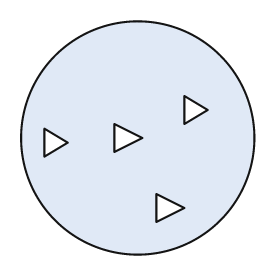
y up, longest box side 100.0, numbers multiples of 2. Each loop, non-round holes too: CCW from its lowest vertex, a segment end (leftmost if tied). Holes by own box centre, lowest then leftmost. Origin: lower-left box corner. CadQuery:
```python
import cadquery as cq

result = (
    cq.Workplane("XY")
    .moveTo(50.0, 50.0)
    .circle(50.0)
    .moveTo(58.0, 14.0)
    .lineTo(70.0, 20.0)
    .lineTo(58.0, 26.0)
    .close()
    .moveTo(10.0, 42.0)
    .lineTo(20.0, 48.0)
    .lineTo(10.0, 54.0)
    .close()
    .moveTo(40.0, 44.0)
    .lineTo(52.0, 50.0)
    .lineTo(40.0, 56.0)
    .close()
    .moveTo(70.0, 56.0)
    .lineTo(80.0, 62.0)
    .lineTo(70.0, 68.0)
    .close()
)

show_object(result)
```